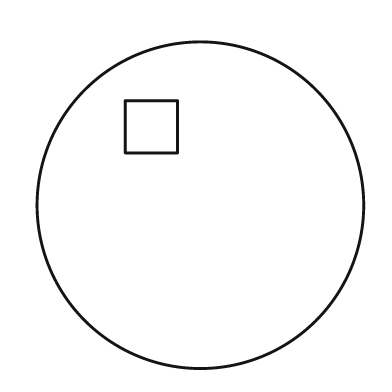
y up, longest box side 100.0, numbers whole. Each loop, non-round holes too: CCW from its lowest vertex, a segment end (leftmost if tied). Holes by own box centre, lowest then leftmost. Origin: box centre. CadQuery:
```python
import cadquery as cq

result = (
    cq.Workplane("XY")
    .moveTo(0.0, 0.0)
    .circle(50.0)
    .moveTo(-23.0, 16.0)
    .lineTo(-7.0, 16.0)
    .lineTo(-7.0, 32.0)
    .lineTo(-23.0, 32.0)
    .close()
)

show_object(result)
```